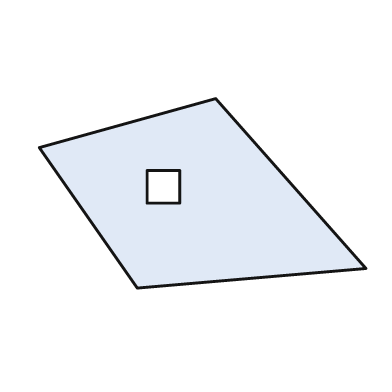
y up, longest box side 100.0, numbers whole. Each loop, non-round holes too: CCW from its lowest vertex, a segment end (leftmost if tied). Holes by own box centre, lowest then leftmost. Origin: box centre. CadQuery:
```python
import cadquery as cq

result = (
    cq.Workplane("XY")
    .moveTo(-20.0, -29.0)
    .lineTo(50.0, -23.0)
    .lineTo(4.0, 29.0)
    .lineTo(-50.0, 14.0)
    .close()
    .moveTo(-17.0, -3.0)
    .lineTo(-7.0, -3.0)
    .lineTo(-7.0, 7.0)
    .lineTo(-17.0, 7.0)
    .close()
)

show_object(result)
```